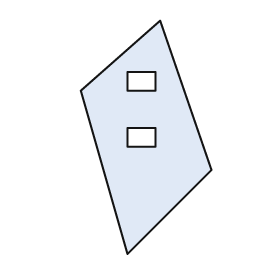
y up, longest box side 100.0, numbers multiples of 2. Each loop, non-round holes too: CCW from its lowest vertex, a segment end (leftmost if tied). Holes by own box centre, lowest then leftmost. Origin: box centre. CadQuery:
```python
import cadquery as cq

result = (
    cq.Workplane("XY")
    .moveTo(-8.0, -50.0)
    .lineTo(28.0, -14.0)
    .lineTo(6.0, 50.0)
    .lineTo(-28.0, 20.0)
    .close()
    .moveTo(-8.0, -4.0)
    .lineTo(4.0, -4.0)
    .lineTo(4.0, 4.0)
    .lineTo(-8.0, 4.0)
    .close()
    .moveTo(-8.0, 20.0)
    .lineTo(4.0, 20.0)
    .lineTo(4.0, 28.0)
    .lineTo(-8.0, 28.0)
    .close()
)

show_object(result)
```